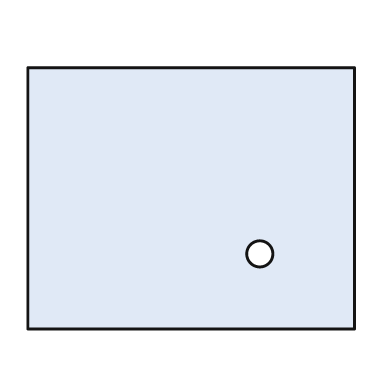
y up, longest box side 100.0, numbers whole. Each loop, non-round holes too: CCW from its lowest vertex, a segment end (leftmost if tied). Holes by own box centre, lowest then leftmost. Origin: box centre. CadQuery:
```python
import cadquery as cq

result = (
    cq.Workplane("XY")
    .moveTo(-50.0, -40.0)
    .lineTo(50.0, -40.0)
    .lineTo(50.0, 40.0)
    .lineTo(-50.0, 40.0)
    .close()
    .moveTo(21.0, -17.0)
    .circle(4.0)
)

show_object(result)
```